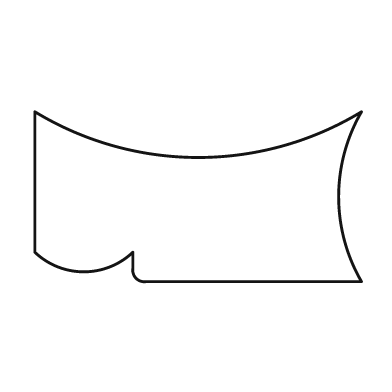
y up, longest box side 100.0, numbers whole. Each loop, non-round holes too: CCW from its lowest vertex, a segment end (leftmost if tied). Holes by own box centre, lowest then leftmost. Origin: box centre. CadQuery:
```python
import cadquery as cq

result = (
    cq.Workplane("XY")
    .moveTo(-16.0, -26.0)
    .lineTo(50.0, -26.0)
    .threePointArc((43.0, 0.0), (50.0, 26.0))
    .threePointArc((0.0, 12.0), (-50.0, 26.0))
    .lineTo(-50.0, -17.0)
    .threePointArc((-35.0, -23.0), (-20.0, -17.0))
    .lineTo(-20.0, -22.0)
    .threePointArc((-19.0, -25.0), (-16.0, -26.0))
    .close()
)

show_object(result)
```